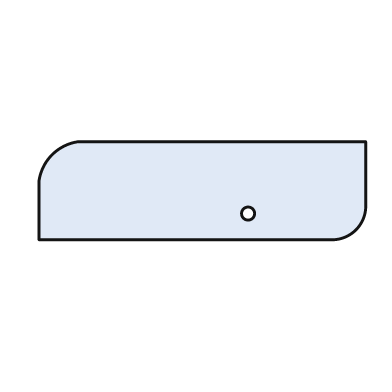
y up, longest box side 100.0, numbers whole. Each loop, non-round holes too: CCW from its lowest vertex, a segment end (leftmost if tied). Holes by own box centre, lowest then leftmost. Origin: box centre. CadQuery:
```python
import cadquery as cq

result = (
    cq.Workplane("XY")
    .moveTo(-50.0, -15.0)
    .lineTo(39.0, -15.0)
    .threePointArc((47.0, -12.0), (50.0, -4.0))
    .lineTo(50.0, 15.0)
    .lineTo(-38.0, 15.0)
    .threePointArc((-46.0, 11.0), (-50.0, 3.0))
    .close()
    .moveTo(14.0, -7.0)
    .circle(2.0)
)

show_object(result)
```